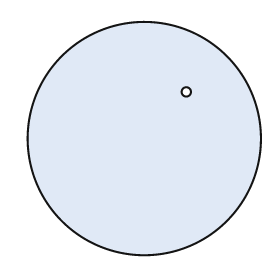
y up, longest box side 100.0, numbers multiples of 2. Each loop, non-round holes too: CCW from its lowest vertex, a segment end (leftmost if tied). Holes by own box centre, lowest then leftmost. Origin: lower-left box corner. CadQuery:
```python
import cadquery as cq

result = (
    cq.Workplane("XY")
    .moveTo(50.0, 50.0)
    .circle(50.0)
    .moveTo(68.0, 70.0)
    .circle(2.0)
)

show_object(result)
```